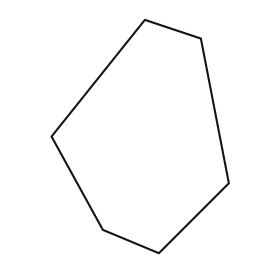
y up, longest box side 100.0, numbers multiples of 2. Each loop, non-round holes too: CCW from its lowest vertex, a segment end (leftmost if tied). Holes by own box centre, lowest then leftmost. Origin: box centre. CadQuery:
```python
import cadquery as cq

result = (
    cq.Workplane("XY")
    .moveTo(8.0, -50.0)
    .lineTo(38.0, -20.0)
    .lineTo(26.0, 42.0)
    .lineTo(2.0, 50.0)
    .lineTo(-38.0, 0.0)
    .lineTo(-16.0, -40.0)
    .close()
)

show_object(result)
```